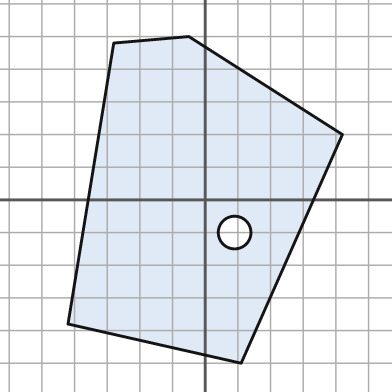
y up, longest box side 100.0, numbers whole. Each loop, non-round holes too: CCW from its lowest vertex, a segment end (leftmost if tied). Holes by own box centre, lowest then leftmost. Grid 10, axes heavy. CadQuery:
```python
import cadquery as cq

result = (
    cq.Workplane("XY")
    .moveTo(11.0, -50.0)
    .lineTo(42.0, 20.0)
    .lineTo(-5.0, 50.0)
    .lineTo(-28.0, 48.0)
    .lineTo(-42.0, -38.0)
    .close()
    .moveTo(9.0, -10.0)
    .circle(5.0)
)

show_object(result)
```